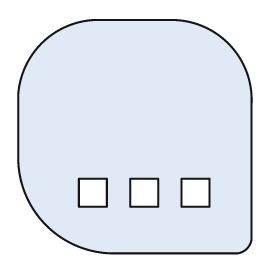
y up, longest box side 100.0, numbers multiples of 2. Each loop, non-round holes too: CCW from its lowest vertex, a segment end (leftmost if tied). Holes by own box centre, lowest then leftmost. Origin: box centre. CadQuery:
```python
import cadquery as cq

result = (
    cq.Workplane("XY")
    .moveTo(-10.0, -50.0)
    .lineTo(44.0, -50.0)
    .threePointArc((48.0, -48.0), (50.0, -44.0))
    .lineTo(50.0, 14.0)
    .threePointArc((40.0, 40.0), (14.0, 50.0))
    .lineTo(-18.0, 50.0)
    .threePointArc((-40.0, 40.0), (-50.0, 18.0))
    .lineTo(-50.0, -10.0)
    .threePointArc((-38.0, -38.0), (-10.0, -50.0))
    .close()
    .moveTo(-24.0, -30.0)
    .lineTo(-12.0, -30.0)
    .lineTo(-12.0, -18.0)
    .lineTo(-24.0, -18.0)
    .close()
    .moveTo(-2.0, -30.0)
    .lineTo(10.0, -30.0)
    .lineTo(10.0, -18.0)
    .lineTo(-2.0, -18.0)
    .close()
    .moveTo(20.0, -30.0)
    .lineTo(32.0, -30.0)
    .lineTo(32.0, -18.0)
    .lineTo(20.0, -18.0)
    .close()
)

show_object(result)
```